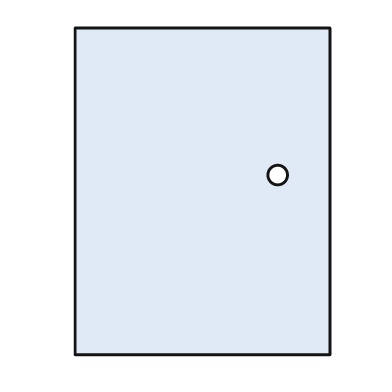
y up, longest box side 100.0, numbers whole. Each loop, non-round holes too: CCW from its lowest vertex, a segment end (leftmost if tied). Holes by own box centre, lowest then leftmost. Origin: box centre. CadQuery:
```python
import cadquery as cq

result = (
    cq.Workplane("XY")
    .moveTo(-39.0, -50.0)
    .lineTo(39.0, -50.0)
    .lineTo(39.0, 50.0)
    .lineTo(-39.0, 50.0)
    .close()
    .moveTo(23.0, 5.0)
    .circle(3.0)
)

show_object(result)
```